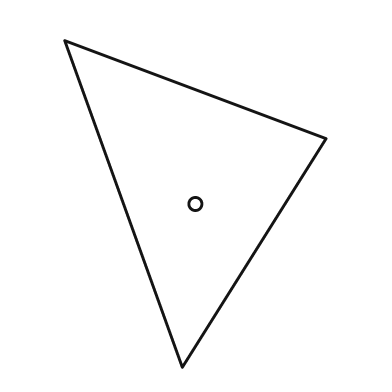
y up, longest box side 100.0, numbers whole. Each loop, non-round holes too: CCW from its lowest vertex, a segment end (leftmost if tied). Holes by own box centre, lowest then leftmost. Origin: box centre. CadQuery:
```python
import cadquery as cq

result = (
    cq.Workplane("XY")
    .moveTo(-4.0, -50.0)
    .lineTo(40.0, 20.0)
    .lineTo(-40.0, 50.0)
    .close()
    .moveTo(0.0, 0.0)
    .circle(2.0)
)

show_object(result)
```